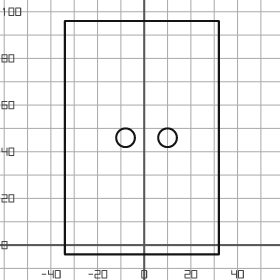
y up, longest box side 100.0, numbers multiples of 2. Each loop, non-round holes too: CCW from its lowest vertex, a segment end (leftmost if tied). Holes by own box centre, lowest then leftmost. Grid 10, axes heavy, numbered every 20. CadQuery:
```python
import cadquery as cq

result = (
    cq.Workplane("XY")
    .moveTo(-34.0, -4.0)
    .lineTo(32.0, -4.0)
    .lineTo(32.0, 96.0)
    .lineTo(-34.0, 96.0)
    .close()
    .moveTo(-8.0, 46.0)
    .circle(4.0)
    .moveTo(10.0, 46.0)
    .circle(4.0)
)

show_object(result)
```